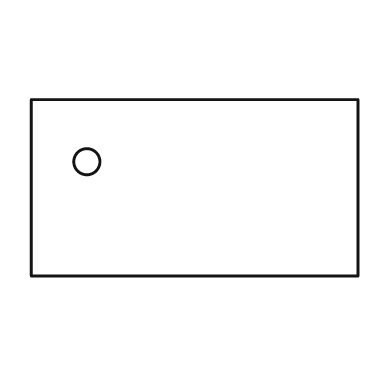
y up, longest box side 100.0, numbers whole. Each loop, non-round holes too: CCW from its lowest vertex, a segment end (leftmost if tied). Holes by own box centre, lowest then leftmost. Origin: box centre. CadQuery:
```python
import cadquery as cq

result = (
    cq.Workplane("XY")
    .moveTo(-50.0, -27.0)
    .lineTo(50.0, -27.0)
    .lineTo(50.0, 27.0)
    .lineTo(-50.0, 27.0)
    .close()
    .moveTo(-33.0, 8.0)
    .circle(4.0)
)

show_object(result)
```